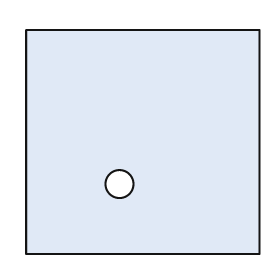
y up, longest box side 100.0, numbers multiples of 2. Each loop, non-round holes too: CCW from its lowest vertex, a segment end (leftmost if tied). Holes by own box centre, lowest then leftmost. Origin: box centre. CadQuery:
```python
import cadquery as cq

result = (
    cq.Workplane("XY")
    .moveTo(-50.0, -48.0)
    .lineTo(50.0, -48.0)
    .lineTo(50.0, 48.0)
    .lineTo(-50.0, 48.0)
    .close()
    .moveTo(-10.0, -18.0)
    .circle(6.0)
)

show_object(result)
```